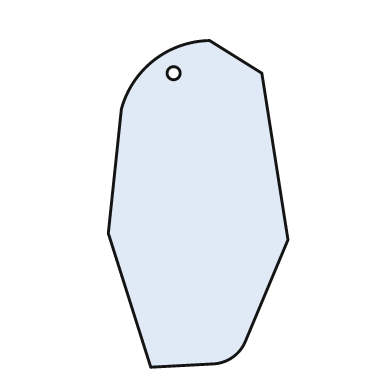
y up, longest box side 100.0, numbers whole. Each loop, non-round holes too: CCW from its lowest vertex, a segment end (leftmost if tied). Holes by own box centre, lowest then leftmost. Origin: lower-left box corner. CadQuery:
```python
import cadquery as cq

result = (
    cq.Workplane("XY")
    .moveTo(13.0, 0.0)
    .lineTo(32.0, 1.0)
    .threePointArc((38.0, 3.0), (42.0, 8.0))
    .lineTo(55.0, 39.0)
    .lineTo(47.0, 90.0)
    .lineTo(31.0, 100.0)
    .threePointArc((14.0, 94.0), (4.0, 79.0))
    .lineTo(0.0, 41.0)
    .close()
    .moveTo(20.0, 90.0)
    .circle(2.0)
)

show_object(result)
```